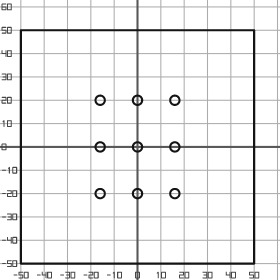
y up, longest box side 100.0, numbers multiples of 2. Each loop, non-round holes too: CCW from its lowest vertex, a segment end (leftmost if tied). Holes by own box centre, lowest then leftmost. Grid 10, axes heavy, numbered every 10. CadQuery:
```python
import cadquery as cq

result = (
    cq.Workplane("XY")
    .moveTo(-50.0, -50.0)
    .lineTo(50.0, -50.0)
    .lineTo(50.0, 50.0)
    .lineTo(-50.0, 50.0)
    .close()
    .moveTo(-16.0, -20.0)
    .circle(2.0)
    .moveTo(0.0, -20.0)
    .circle(2.0)
    .moveTo(16.0, -20.0)
    .circle(2.0)
    .moveTo(-16.0, 0.0)
    .circle(2.0)
    .moveTo(0.0, 0.0)
    .circle(2.0)
    .moveTo(16.0, 0.0)
    .circle(2.0)
    .moveTo(-16.0, 20.0)
    .circle(2.0)
    .moveTo(0.0, 20.0)
    .circle(2.0)
    .moveTo(16.0, 20.0)
    .circle(2.0)
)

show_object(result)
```